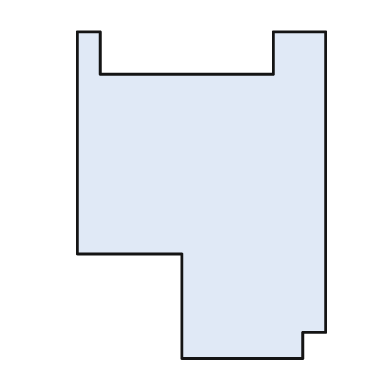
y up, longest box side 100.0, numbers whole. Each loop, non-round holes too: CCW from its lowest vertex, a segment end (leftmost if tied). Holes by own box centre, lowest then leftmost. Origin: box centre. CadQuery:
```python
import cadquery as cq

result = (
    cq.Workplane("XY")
    .moveTo(-6.0, -50.0)
    .lineTo(31.0, -50.0)
    .lineTo(31.0, -42.0)
    .lineTo(38.0, -42.0)
    .lineTo(38.0, 50.0)
    .lineTo(22.0, 50.0)
    .lineTo(22.0, 37.0)
    .lineTo(-31.0, 37.0)
    .lineTo(-31.0, 50.0)
    .lineTo(-38.0, 50.0)
    .lineTo(-38.0, -18.0)
    .lineTo(-6.0, -18.0)
    .close()
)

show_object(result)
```